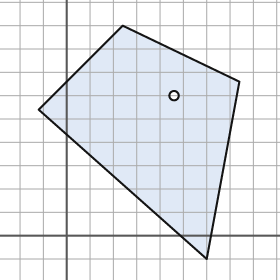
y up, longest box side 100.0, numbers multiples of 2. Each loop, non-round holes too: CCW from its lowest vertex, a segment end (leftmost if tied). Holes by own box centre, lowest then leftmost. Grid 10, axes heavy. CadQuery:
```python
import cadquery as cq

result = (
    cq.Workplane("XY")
    .moveTo(60.0, -10.0)
    .lineTo(74.0, 66.0)
    .lineTo(24.0, 90.0)
    .lineTo(-12.0, 54.0)
    .close()
    .moveTo(46.0, 60.0)
    .circle(2.0)
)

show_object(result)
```